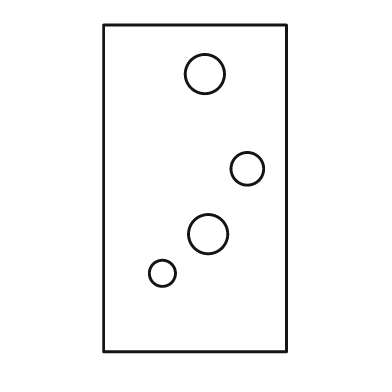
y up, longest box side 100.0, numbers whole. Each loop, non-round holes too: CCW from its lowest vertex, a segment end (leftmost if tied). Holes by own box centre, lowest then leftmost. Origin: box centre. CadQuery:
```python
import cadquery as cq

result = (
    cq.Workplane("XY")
    .moveTo(-28.0, -50.0)
    .lineTo(28.0, -50.0)
    .lineTo(28.0, 50.0)
    .lineTo(-28.0, 50.0)
    .close()
    .moveTo(-10.0, -26.0)
    .circle(4.0)
    .moveTo(4.0, -14.0)
    .circle(6.0)
    .moveTo(16.0, 6.0)
    .circle(5.0)
    .moveTo(3.0, 35.0)
    .circle(6.0)
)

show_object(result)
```